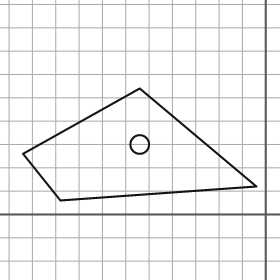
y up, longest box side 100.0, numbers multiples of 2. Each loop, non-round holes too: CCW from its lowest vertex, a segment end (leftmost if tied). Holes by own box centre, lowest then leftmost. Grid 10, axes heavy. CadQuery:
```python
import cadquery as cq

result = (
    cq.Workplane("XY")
    .moveTo(-88.0, 6.0)
    .lineTo(-4.0, 12.0)
    .lineTo(-54.0, 54.0)
    .lineTo(-104.0, 26.0)
    .close()
    .moveTo(-54.0, 30.0)
    .circle(4.0)
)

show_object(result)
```